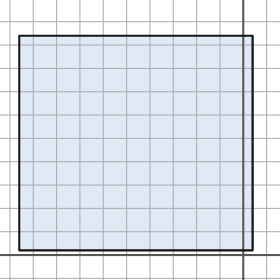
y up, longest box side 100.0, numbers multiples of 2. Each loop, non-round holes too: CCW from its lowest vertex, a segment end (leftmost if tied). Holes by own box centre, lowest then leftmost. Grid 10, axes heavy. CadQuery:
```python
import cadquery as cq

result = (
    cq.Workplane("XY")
    .moveTo(-96.0, 2.0)
    .lineTo(4.0, 2.0)
    .lineTo(4.0, 94.0)
    .lineTo(-96.0, 94.0)
    .close()
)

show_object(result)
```